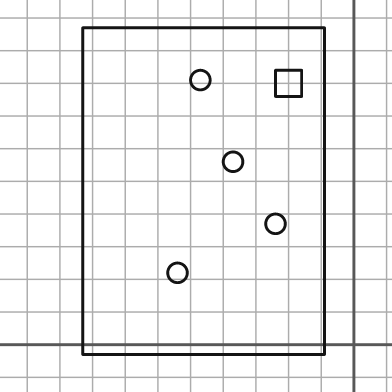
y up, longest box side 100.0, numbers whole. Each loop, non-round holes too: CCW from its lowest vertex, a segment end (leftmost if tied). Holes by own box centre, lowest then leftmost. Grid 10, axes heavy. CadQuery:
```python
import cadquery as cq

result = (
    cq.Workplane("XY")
    .moveTo(-83.0, -3.0)
    .lineTo(-9.0, -3.0)
    .lineTo(-9.0, 97.0)
    .lineTo(-83.0, 97.0)
    .close()
    .moveTo(-54.0, 22.0)
    .circle(3.0)
    .moveTo(-24.0, 37.0)
    .circle(3.0)
    .moveTo(-37.0, 56.0)
    .circle(3.0)
    .moveTo(-24.0, 76.0)
    .lineTo(-16.0, 76.0)
    .lineTo(-16.0, 84.0)
    .lineTo(-24.0, 84.0)
    .close()
    .moveTo(-47.0, 81.0)
    .circle(3.0)
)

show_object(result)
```